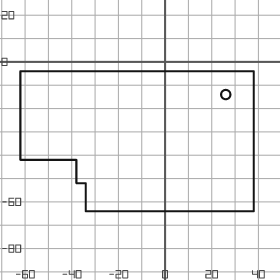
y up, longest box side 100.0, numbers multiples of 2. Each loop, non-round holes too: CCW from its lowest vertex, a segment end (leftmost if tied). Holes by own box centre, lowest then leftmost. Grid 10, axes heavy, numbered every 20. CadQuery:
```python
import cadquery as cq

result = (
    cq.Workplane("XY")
    .moveTo(-34.0, -64.0)
    .lineTo(38.0, -64.0)
    .lineTo(38.0, -4.0)
    .lineTo(-62.0, -4.0)
    .lineTo(-62.0, -42.0)
    .lineTo(-38.0, -42.0)
    .lineTo(-38.0, -52.0)
    .lineTo(-34.0, -52.0)
    .close()
    .moveTo(26.0, -14.0)
    .circle(2.0)
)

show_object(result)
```